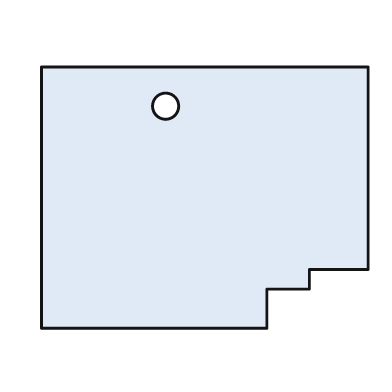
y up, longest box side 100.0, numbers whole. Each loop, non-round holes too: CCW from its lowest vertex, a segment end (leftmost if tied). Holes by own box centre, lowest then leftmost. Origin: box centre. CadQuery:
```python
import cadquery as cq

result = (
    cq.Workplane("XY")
    .moveTo(-50.0, -40.0)
    .lineTo(19.0, -40.0)
    .lineTo(19.0, -28.0)
    .lineTo(32.0, -28.0)
    .lineTo(32.0, -22.0)
    .lineTo(50.0, -22.0)
    .lineTo(50.0, 40.0)
    .lineTo(-50.0, 40.0)
    .close()
    .moveTo(-12.0, 28.0)
    .circle(4.0)
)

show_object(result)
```